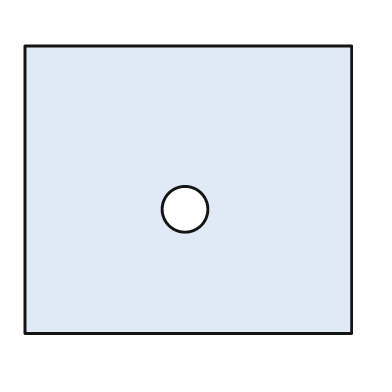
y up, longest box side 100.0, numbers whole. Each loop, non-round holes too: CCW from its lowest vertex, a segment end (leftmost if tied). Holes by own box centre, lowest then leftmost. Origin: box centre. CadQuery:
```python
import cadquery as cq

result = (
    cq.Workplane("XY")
    .moveTo(-50.0, -44.0)
    .lineTo(50.0, -44.0)
    .lineTo(50.0, 44.0)
    .lineTo(-50.0, 44.0)
    .close()
    .moveTo(-1.0, -6.0)
    .circle(7.0)
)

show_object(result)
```